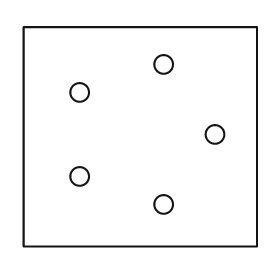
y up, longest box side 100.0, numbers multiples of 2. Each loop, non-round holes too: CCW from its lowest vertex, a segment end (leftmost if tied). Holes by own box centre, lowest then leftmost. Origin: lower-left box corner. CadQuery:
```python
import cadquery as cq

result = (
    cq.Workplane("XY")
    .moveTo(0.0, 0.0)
    .lineTo(100.0, 0.0)
    .lineTo(100.0, 94.0)
    .lineTo(0.0, 94.0)
    .close()
    .moveTo(60.0, 18.0)
    .circle(4.0)
    .moveTo(24.0, 30.0)
    .circle(4.0)
    .moveTo(82.0, 48.0)
    .circle(4.0)
    .moveTo(24.0, 66.0)
    .circle(4.0)
    .moveTo(60.0, 78.0)
    .circle(4.0)
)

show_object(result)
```